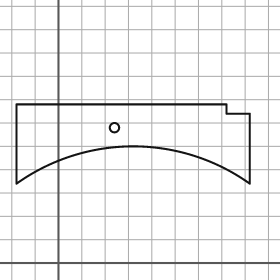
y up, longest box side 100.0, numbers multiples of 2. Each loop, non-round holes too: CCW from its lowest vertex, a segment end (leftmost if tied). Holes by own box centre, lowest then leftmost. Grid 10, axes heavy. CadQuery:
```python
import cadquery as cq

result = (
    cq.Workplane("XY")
    .moveTo(-18.0, 34.0)
    .threePointArc((32.0, 50.0), (82.0, 34.0))
    .lineTo(82.0, 64.0)
    .lineTo(72.0, 64.0)
    .lineTo(72.0, 68.0)
    .lineTo(-18.0, 68.0)
    .close()
    .moveTo(24.0, 58.0)
    .circle(2.0)
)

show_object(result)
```